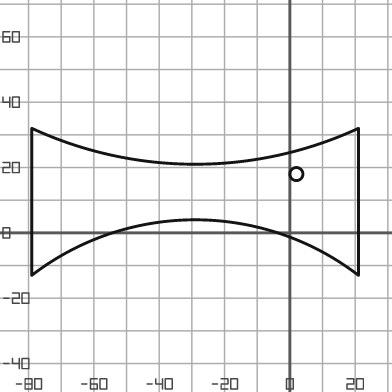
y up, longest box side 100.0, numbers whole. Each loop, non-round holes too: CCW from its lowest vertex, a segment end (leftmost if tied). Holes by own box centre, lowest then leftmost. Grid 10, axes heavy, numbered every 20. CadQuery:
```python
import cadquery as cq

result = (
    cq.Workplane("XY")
    .moveTo(-79.0, -13.0)
    .threePointArc((-29.0, 4.0), (21.0, -13.0))
    .lineTo(21.0, 32.0)
    .threePointArc((-29.0, 21.0), (-79.0, 32.0))
    .close()
    .moveTo(2.0, 18.0)
    .circle(2.0)
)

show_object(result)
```